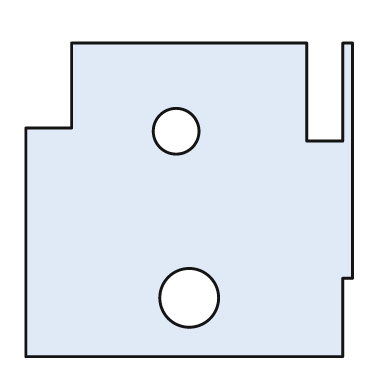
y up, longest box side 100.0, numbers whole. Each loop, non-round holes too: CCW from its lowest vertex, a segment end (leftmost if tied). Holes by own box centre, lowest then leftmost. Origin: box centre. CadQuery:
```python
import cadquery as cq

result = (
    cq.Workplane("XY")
    .moveTo(-50.0, -48.0)
    .lineTo(47.0, -48.0)
    .lineTo(47.0, -24.0)
    .lineTo(50.0, -24.0)
    .lineTo(50.0, 48.0)
    .lineTo(47.0, 48.0)
    .lineTo(47.0, 18.0)
    .lineTo(36.0, 18.0)
    .lineTo(36.0, 48.0)
    .lineTo(-36.0, 48.0)
    .lineTo(-36.0, 22.0)
    .lineTo(-50.0, 22.0)
    .close()
    .moveTo(0.0, -30.0)
    .circle(9.0)
    .moveTo(-4.0, 21.0)
    .circle(7.0)
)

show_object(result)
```